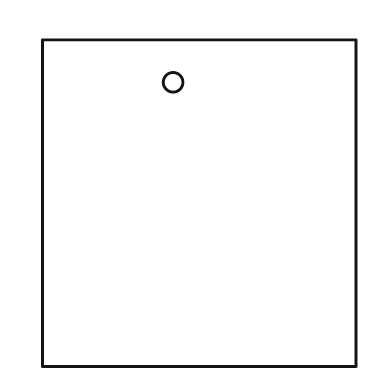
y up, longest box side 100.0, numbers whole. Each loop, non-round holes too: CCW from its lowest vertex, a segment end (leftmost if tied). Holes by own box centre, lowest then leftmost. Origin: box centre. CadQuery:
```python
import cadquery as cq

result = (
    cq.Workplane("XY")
    .moveTo(-48.0, -50.0)
    .lineTo(48.0, -50.0)
    .lineTo(48.0, 50.0)
    .lineTo(-48.0, 50.0)
    .close()
    .moveTo(-8.0, 37.0)
    .circle(3.0)
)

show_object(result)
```